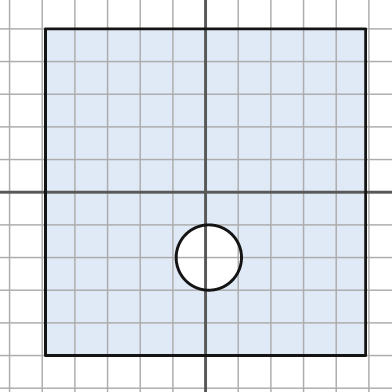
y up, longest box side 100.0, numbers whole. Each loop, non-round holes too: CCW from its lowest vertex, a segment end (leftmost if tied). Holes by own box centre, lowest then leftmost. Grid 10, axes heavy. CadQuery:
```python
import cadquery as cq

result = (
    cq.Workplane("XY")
    .moveTo(-49.0, -50.0)
    .lineTo(49.0, -50.0)
    .lineTo(49.0, 50.0)
    .lineTo(-49.0, 50.0)
    .close()
    .moveTo(1.0, -20.0)
    .circle(10.0)
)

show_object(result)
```